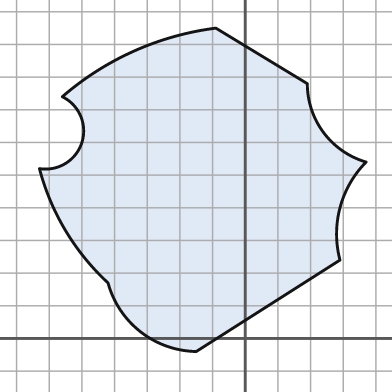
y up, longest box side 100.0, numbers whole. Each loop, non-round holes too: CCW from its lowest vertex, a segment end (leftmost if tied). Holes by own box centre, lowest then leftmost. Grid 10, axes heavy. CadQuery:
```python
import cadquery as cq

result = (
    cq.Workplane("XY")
    .moveTo(-15.0, -4.0)
    .lineTo(29.0, 24.0)
    .threePointArc((29.0, 40.0), (37.0, 54.0))
    .threePointArc((24.0, 63.0), (19.0, 78.0))
    .lineTo(-9.0, 95.0)
    .threePointArc((-34.0, 88.0), (-56.0, 74.0))
    .threePointArc((-50.0, 60.0), (-63.0, 52.0))
    .threePointArc((-55.0, 33.0), (-42.0, 17.0))
    .threePointArc((-32.0, 2.0), (-15.0, -4.0))
    .close()
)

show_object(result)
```